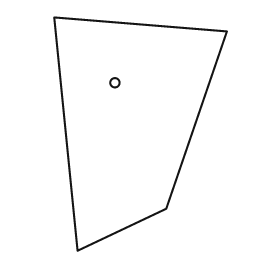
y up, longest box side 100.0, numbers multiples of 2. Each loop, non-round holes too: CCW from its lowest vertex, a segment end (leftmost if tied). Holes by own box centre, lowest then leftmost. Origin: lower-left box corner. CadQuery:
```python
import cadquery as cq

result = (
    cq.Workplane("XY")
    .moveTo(10.0, 0.0)
    .lineTo(48.0, 18.0)
    .lineTo(74.0, 94.0)
    .lineTo(0.0, 100.0)
    .close()
    .moveTo(26.0, 72.0)
    .circle(2.0)
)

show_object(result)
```